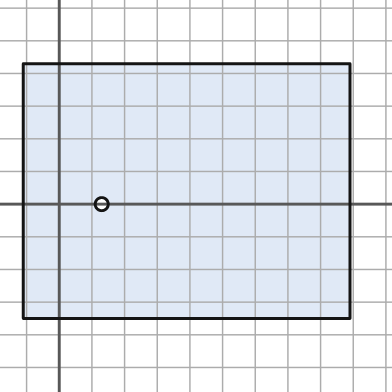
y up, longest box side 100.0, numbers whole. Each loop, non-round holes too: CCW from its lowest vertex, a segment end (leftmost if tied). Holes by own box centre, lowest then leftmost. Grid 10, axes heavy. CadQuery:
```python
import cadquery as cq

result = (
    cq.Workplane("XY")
    .moveTo(-11.0, -35.0)
    .lineTo(89.0, -35.0)
    .lineTo(89.0, 43.0)
    .lineTo(-11.0, 43.0)
    .close()
    .moveTo(13.0, 0.0)
    .circle(2.0)
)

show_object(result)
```